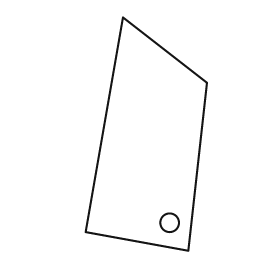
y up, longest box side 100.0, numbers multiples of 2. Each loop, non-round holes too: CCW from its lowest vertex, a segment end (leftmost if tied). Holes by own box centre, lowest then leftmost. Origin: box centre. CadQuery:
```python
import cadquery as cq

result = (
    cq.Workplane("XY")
    .moveTo(18.0, -50.0)
    .lineTo(26.0, 22.0)
    .lineTo(-10.0, 50.0)
    .lineTo(-26.0, -42.0)
    .close()
    .moveTo(10.0, -38.0)
    .circle(4.0)
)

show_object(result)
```